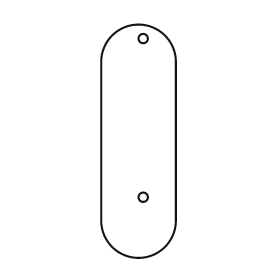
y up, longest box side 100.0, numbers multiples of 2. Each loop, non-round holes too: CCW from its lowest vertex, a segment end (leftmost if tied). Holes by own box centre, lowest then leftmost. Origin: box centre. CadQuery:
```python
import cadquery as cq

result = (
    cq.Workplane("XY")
    .moveTo(-16.0, -34.0)
    .threePointArc((0.0, -50.0), (16.0, -34.0))
    .lineTo(16.0, 34.0)
    .threePointArc((0.0, 50.0), (-16.0, 34.0))
    .close()
    .moveTo(2.0, -24.0)
    .circle(2.0)
    .moveTo(2.0, 44.0)
    .circle(2.0)
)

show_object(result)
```